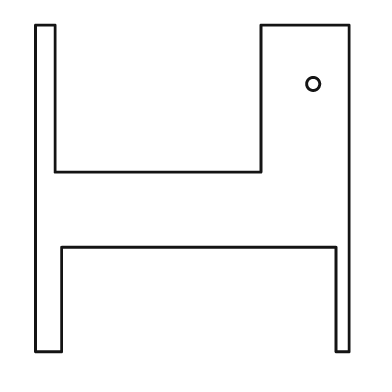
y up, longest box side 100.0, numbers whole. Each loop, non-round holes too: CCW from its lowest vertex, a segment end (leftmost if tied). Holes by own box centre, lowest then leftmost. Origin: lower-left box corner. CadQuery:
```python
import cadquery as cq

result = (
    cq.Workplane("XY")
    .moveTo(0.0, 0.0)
    .lineTo(8.0, 0.0)
    .lineTo(8.0, 32.0)
    .lineTo(92.0, 32.0)
    .lineTo(92.0, 0.0)
    .lineTo(96.0, 0.0)
    .lineTo(96.0, 100.0)
    .lineTo(69.0, 100.0)
    .lineTo(69.0, 55.0)
    .lineTo(6.0, 55.0)
    .lineTo(6.0, 100.0)
    .lineTo(0.0, 100.0)
    .close()
    .moveTo(85.0, 82.0)
    .circle(2.0)
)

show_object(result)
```